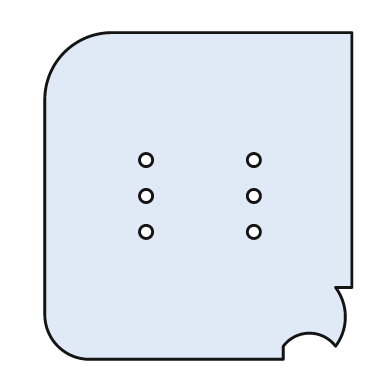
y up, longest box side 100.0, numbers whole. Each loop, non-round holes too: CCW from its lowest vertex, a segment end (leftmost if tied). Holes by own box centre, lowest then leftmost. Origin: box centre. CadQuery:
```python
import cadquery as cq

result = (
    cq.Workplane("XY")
    .moveTo(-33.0, -50.0)
    .lineTo(26.0, -50.0)
    .lineTo(26.0, -46.0)
    .threePointArc((34.0, -42.0), (42.0, -46.0))
    .threePointArc((45.0, -37.0), (42.0, -28.0))
    .lineTo(47.0, -28.0)
    .lineTo(47.0, 50.0)
    .lineTo(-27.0, 50.0)
    .threePointArc((-41.0, 44.0), (-47.0, 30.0))
    .lineTo(-47.0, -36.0)
    .threePointArc((-43.0, -46.0), (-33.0, -50.0))
    .close()
    .moveTo(-16.0, -11.0)
    .circle(2.0)
    .moveTo(17.0, -11.0)
    .circle(2.0)
    .moveTo(-16.0, 0.0)
    .circle(2.0)
    .moveTo(17.0, 0.0)
    .circle(2.0)
    .moveTo(-16.0, 11.0)
    .circle(2.0)
    .moveTo(17.0, 11.0)
    .circle(2.0)
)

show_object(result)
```